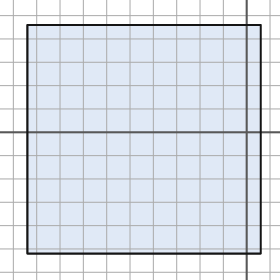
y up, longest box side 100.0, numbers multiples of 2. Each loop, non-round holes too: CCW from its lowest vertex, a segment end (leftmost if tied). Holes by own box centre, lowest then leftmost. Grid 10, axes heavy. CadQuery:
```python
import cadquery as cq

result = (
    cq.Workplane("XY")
    .moveTo(-94.0, -52.0)
    .lineTo(6.0, -52.0)
    .lineTo(6.0, 46.0)
    .lineTo(-94.0, 46.0)
    .close()
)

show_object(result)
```